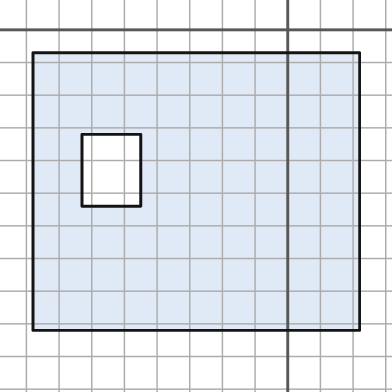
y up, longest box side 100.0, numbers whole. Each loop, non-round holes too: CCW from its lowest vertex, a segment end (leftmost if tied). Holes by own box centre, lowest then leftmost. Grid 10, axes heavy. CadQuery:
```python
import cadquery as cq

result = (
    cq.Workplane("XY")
    .moveTo(-78.0, -92.0)
    .lineTo(22.0, -92.0)
    .lineTo(22.0, -7.0)
    .lineTo(-78.0, -7.0)
    .close()
    .moveTo(-63.0, -54.0)
    .lineTo(-45.0, -54.0)
    .lineTo(-45.0, -32.0)
    .lineTo(-63.0, -32.0)
    .close()
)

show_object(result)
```